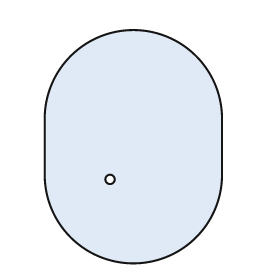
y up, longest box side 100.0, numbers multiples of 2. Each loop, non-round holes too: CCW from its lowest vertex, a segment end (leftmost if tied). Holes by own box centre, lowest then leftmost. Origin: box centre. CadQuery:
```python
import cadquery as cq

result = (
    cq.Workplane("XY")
    .moveTo(-38.0, -12.0)
    .threePointArc((0.0, -50.0), (38.0, -12.0))
    .lineTo(38.0, 12.0)
    .threePointArc((0.0, 50.0), (-38.0, 12.0))
    .close()
    .moveTo(-10.0, -14.0)
    .circle(2.0)
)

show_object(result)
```